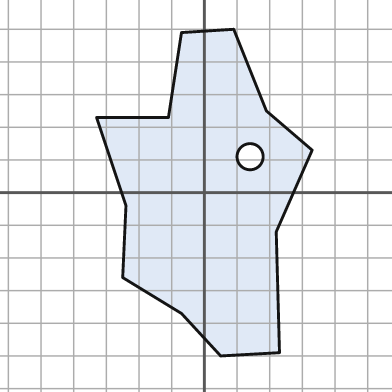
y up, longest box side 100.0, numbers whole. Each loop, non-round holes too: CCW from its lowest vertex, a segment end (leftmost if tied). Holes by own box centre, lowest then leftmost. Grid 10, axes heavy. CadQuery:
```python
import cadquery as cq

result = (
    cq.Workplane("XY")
    .moveTo(5.0, -50.0)
    .lineTo(23.0, -49.0)
    .lineTo(22.0, -12.0)
    .lineTo(33.0, 13.0)
    .lineTo(19.0, 25.0)
    .lineTo(9.0, 50.0)
    .lineTo(-7.0, 49.0)
    .lineTo(-11.0, 23.0)
    .lineTo(-33.0, 23.0)
    .lineTo(-24.0, -4.0)
    .lineTo(-25.0, -26.0)
    .lineTo(-7.0, -37.0)
    .close()
    .moveTo(14.0, 11.0)
    .circle(4.0)
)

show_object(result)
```